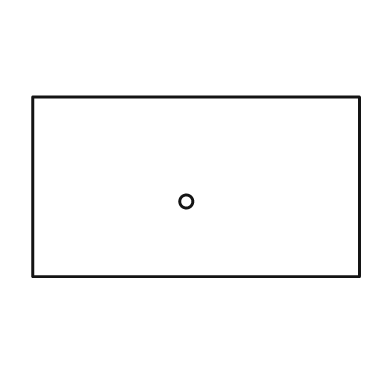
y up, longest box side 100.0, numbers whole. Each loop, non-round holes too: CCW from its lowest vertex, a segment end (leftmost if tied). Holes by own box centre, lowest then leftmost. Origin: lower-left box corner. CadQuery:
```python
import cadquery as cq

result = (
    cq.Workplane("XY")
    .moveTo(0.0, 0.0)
    .lineTo(100.0, 0.0)
    .lineTo(100.0, 55.0)
    .lineTo(0.0, 55.0)
    .close()
    .moveTo(47.0, 23.0)
    .circle(2.0)
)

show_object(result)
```